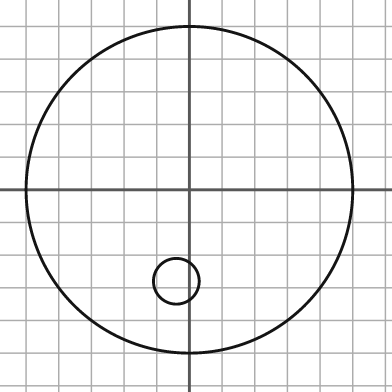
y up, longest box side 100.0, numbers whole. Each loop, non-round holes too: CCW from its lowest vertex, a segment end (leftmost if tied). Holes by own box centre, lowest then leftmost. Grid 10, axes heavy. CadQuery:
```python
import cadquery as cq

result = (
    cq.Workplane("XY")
    .moveTo(0.0, 0.0)
    .circle(50.0)
    .moveTo(-4.0, -28.0)
    .circle(7.0)
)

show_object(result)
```